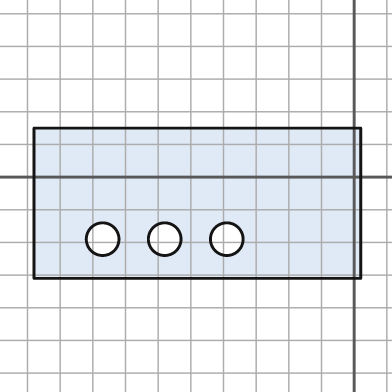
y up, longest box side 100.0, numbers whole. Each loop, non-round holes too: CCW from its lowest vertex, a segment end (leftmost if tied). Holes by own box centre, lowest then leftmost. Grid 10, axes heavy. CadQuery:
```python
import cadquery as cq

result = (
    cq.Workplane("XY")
    .moveTo(-98.0, -31.0)
    .lineTo(2.0, -31.0)
    .lineTo(2.0, 15.0)
    .lineTo(-98.0, 15.0)
    .close()
    .moveTo(-77.0, -19.0)
    .circle(5.0)
    .moveTo(-58.0, -19.0)
    .circle(5.0)
    .moveTo(-39.0, -19.0)
    .circle(5.0)
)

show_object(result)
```